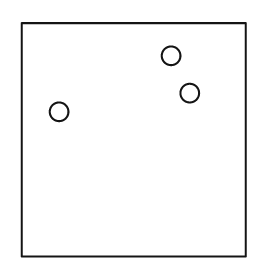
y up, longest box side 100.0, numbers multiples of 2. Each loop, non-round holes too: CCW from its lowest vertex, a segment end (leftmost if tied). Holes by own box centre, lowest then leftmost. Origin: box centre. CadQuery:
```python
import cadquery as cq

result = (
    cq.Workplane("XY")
    .moveTo(-48.0, -50.0)
    .lineTo(48.0, -50.0)
    .lineTo(48.0, 50.0)
    .lineTo(-48.0, 50.0)
    .close()
    .moveTo(-32.0, 12.0)
    .circle(4.0)
    .moveTo(24.0, 20.0)
    .circle(4.0)
    .moveTo(16.0, 36.0)
    .circle(4.0)
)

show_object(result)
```